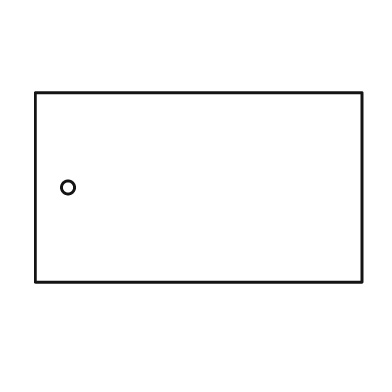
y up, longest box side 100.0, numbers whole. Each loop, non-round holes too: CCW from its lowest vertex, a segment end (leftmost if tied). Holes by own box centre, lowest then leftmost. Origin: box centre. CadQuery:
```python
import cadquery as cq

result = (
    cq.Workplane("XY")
    .moveTo(-50.0, -29.0)
    .lineTo(50.0, -29.0)
    .lineTo(50.0, 29.0)
    .lineTo(-50.0, 29.0)
    .close()
    .moveTo(-40.0, 0.0)
    .circle(2.0)
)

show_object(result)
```